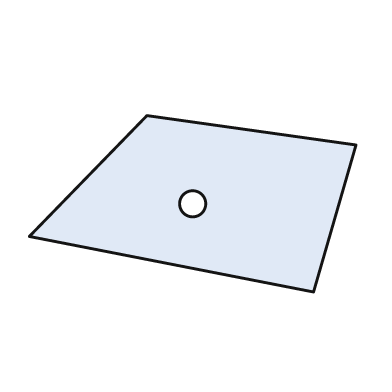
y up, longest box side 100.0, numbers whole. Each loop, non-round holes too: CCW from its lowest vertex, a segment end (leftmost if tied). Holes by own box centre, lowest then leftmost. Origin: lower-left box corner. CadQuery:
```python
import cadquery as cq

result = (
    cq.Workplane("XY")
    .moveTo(87.0, 0.0)
    .lineTo(100.0, 45.0)
    .lineTo(36.0, 54.0)
    .lineTo(0.0, 17.0)
    .close()
    .moveTo(50.0, 27.0)
    .circle(4.0)
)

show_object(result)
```